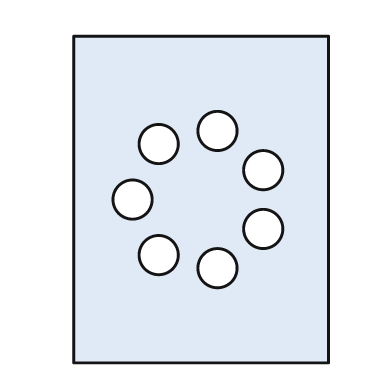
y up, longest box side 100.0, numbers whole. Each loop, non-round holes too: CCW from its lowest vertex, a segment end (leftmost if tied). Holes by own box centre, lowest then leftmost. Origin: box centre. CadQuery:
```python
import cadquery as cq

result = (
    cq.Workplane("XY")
    .moveTo(-39.0, -50.0)
    .lineTo(39.0, -50.0)
    .lineTo(39.0, 50.0)
    .lineTo(-39.0, 50.0)
    .close()
    .moveTo(5.0, -21.0)
    .circle(6.0)
    .moveTo(-13.0, -17.0)
    .circle(6.0)
    .moveTo(19.0, -9.0)
    .circle(6.0)
    .moveTo(-21.0, 0.0)
    .circle(6.0)
    .moveTo(19.0, 9.0)
    .circle(6.0)
    .moveTo(-13.0, 17.0)
    .circle(6.0)
    .moveTo(5.0, 21.0)
    .circle(6.0)
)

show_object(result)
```